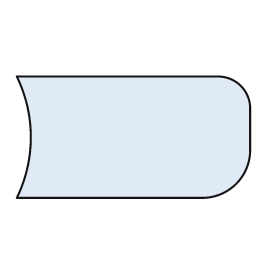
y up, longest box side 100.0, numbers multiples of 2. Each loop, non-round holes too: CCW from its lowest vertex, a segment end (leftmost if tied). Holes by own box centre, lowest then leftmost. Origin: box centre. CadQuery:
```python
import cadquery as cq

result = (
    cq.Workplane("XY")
    .moveTo(-50.0, -26.0)
    .lineTo(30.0, -26.0)
    .threePointArc((44.0, -20.0), (50.0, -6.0))
    .lineTo(50.0, 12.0)
    .threePointArc((46.0, 22.0), (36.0, 26.0))
    .lineTo(-50.0, 26.0)
    .threePointArc((-44.0, 0.0), (-50.0, -26.0))
    .close()
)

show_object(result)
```